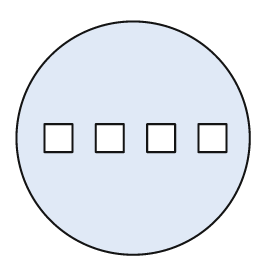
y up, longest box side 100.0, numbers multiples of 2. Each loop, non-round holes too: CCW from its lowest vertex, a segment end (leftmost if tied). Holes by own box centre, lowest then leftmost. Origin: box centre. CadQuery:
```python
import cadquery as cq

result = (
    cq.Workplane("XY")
    .moveTo(0.0, 0.0)
    .circle(50.0)
    .moveTo(-38.0, -6.0)
    .lineTo(-26.0, -6.0)
    .lineTo(-26.0, 6.0)
    .lineTo(-38.0, 6.0)
    .close()
    .moveTo(-16.0, -6.0)
    .lineTo(-4.0, -6.0)
    .lineTo(-4.0, 6.0)
    .lineTo(-16.0, 6.0)
    .close()
    .moveTo(6.0, -6.0)
    .lineTo(18.0, -6.0)
    .lineTo(18.0, 6.0)
    .lineTo(6.0, 6.0)
    .close()
    .moveTo(28.0, -6.0)
    .lineTo(40.0, -6.0)
    .lineTo(40.0, 6.0)
    .lineTo(28.0, 6.0)
    .close()
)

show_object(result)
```